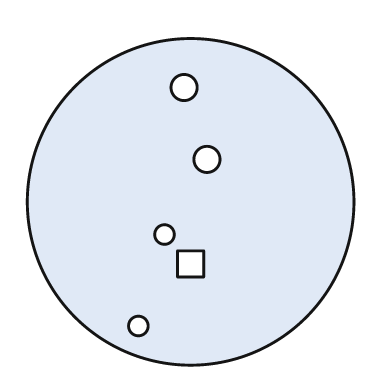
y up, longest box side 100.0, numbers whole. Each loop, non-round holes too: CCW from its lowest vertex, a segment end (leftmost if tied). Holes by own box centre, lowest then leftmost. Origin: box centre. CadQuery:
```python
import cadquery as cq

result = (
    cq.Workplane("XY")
    .moveTo(0.0, 0.0)
    .circle(50.0)
    .moveTo(-16.0, -38.0)
    .circle(3.0)
    .moveTo(-4.0, -23.0)
    .lineTo(4.0, -23.0)
    .lineTo(4.0, -15.0)
    .lineTo(-4.0, -15.0)
    .close()
    .moveTo(-8.0, -10.0)
    .circle(3.0)
    .moveTo(5.0, 13.0)
    .circle(4.0)
    .moveTo(-2.0, 35.0)
    .circle(4.0)
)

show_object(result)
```